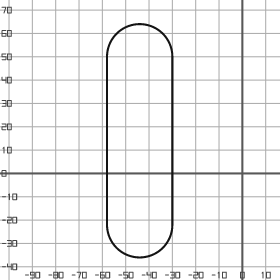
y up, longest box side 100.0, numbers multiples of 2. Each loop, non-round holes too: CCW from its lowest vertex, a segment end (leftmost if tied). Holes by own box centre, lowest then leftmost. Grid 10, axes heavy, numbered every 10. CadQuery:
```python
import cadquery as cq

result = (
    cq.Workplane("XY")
    .moveTo(-58.0, -22.0)
    .threePointArc((-44.0, -36.0), (-30.0, -22.0))
    .lineTo(-30.0, 50.0)
    .threePointArc((-44.0, 64.0), (-58.0, 50.0))
    .close()
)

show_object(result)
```